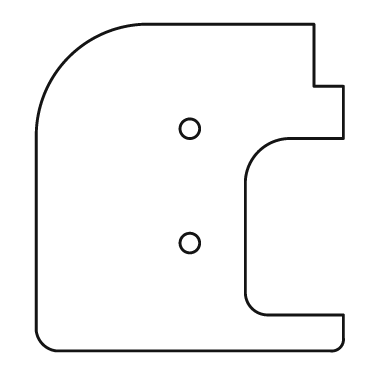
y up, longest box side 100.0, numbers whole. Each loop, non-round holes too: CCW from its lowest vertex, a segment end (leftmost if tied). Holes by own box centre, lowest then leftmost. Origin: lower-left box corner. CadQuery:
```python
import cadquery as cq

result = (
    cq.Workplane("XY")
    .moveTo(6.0, 0.0)
    .lineTo(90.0, 0.0)
    .threePointArc((93.0, 1.0), (94.0, 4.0))
    .lineTo(94.0, 11.0)
    .lineTo(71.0, 11.0)
    .threePointArc((66.0, 13.0), (64.0, 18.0))
    .lineTo(64.0, 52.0)
    .threePointArc((68.0, 61.0), (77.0, 65.0))
    .lineTo(94.0, 65.0)
    .lineTo(94.0, 81.0)
    .lineTo(85.0, 81.0)
    .lineTo(85.0, 100.0)
    .lineTo(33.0, 100.0)
    .threePointArc((10.0, 90.0), (0.0, 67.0))
    .lineTo(0.0, 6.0)
    .threePointArc((2.0, 2.0), (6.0, 0.0))
    .close()
    .moveTo(47.0, 33.0)
    .circle(3.0)
    .moveTo(47.0, 68.0)
    .circle(3.0)
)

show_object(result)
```